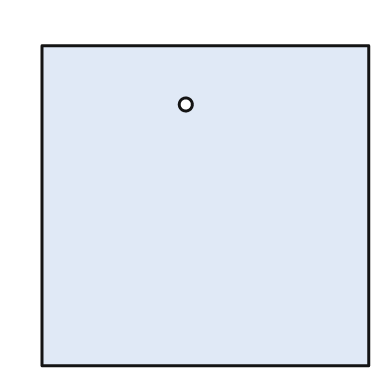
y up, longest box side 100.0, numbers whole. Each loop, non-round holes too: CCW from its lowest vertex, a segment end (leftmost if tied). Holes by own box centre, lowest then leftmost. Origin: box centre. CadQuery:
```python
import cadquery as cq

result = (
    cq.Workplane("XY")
    .moveTo(-50.0, -49.0)
    .lineTo(50.0, -49.0)
    .lineTo(50.0, 49.0)
    .lineTo(-50.0, 49.0)
    .close()
    .moveTo(-6.0, 31.0)
    .circle(2.0)
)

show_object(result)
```